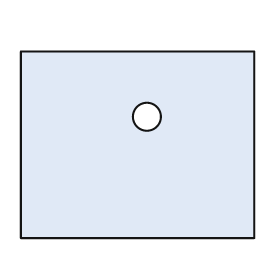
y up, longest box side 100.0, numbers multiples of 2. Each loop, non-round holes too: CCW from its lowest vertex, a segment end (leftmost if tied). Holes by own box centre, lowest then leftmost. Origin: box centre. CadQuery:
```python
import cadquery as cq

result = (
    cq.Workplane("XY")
    .moveTo(-50.0, -40.0)
    .lineTo(50.0, -40.0)
    .lineTo(50.0, 40.0)
    .lineTo(-50.0, 40.0)
    .close()
    .moveTo(4.0, 12.0)
    .circle(6.0)
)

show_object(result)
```